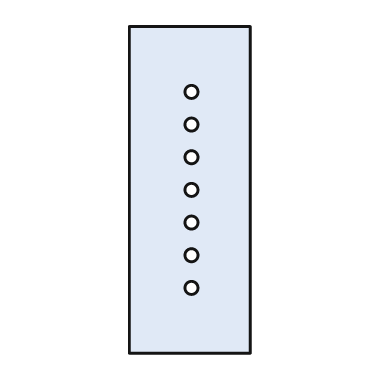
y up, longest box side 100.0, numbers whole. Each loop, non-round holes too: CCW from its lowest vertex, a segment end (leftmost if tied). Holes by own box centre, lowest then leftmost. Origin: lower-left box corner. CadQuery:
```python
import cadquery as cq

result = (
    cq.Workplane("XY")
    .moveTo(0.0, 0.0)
    .lineTo(37.0, 0.0)
    .lineTo(37.0, 100.0)
    .lineTo(0.0, 100.0)
    .close()
    .moveTo(19.0, 20.0)
    .circle(2.0)
    .moveTo(19.0, 30.0)
    .circle(2.0)
    .moveTo(19.0, 40.0)
    .circle(2.0)
    .moveTo(19.0, 50.0)
    .circle(2.0)
    .moveTo(19.0, 60.0)
    .circle(2.0)
    .moveTo(19.0, 70.0)
    .circle(2.0)
    .moveTo(19.0, 80.0)
    .circle(2.0)
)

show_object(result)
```